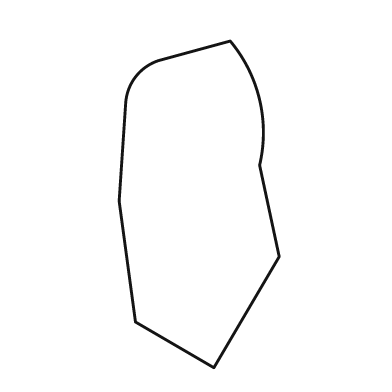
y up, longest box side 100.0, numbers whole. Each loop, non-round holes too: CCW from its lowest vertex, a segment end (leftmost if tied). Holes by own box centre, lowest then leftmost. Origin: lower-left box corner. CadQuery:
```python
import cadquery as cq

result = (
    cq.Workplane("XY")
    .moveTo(29.0, 0.0)
    .lineTo(49.0, 34.0)
    .lineTo(43.0, 62.0)
    .threePointArc((43.0, 82.0), (34.0, 100.0))
    .lineTo(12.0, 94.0)
    .threePointArc((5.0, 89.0), (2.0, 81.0))
    .lineTo(0.0, 51.0)
    .lineTo(5.0, 14.0)
    .close()
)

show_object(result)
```